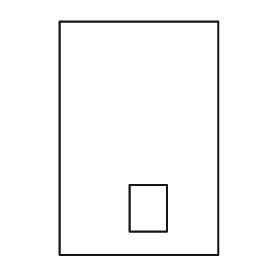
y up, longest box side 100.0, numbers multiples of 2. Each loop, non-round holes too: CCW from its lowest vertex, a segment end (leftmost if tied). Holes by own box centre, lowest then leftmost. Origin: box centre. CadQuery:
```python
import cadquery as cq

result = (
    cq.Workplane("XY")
    .moveTo(-34.0, -50.0)
    .lineTo(34.0, -50.0)
    .lineTo(34.0, 50.0)
    .lineTo(-34.0, 50.0)
    .close()
    .moveTo(-4.0, -40.0)
    .lineTo(12.0, -40.0)
    .lineTo(12.0, -20.0)
    .lineTo(-4.0, -20.0)
    .close()
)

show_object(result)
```